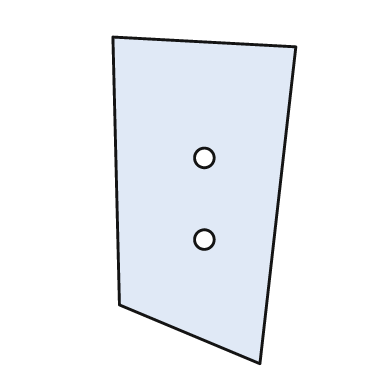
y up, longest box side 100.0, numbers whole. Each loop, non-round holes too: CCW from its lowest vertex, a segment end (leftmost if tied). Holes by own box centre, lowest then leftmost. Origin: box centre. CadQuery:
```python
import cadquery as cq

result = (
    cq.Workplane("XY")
    .moveTo(17.0, -50.0)
    .lineTo(28.0, 47.0)
    .lineTo(-28.0, 50.0)
    .lineTo(-26.0, -32.0)
    .close()
    .moveTo(0.0, -12.0)
    .circle(3.0)
    .moveTo(0.0, 13.0)
    .circle(3.0)
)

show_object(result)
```